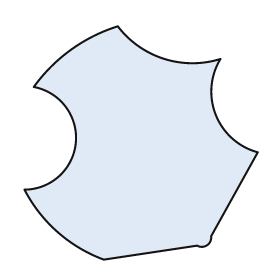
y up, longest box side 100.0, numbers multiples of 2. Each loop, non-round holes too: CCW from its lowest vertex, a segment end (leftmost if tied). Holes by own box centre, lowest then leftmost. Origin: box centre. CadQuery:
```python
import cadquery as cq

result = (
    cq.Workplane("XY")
    .moveTo(-16.0, -50.0)
    .lineTo(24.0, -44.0)
    .threePointArc((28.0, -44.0), (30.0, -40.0))
    .lineTo(50.0, -4.0)
    .threePointArc((32.0, 12.0), (34.0, 36.0))
    .threePointArc((10.0, 36.0), (-10.0, 50.0))
    .threePointArc((-30.0, 40.0), (-46.0, 24.0))
    .threePointArc((-28.0, 0.0), (-50.0, -20.0))
    .threePointArc((-36.0, -38.0), (-16.0, -50.0))
    .close()
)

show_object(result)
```